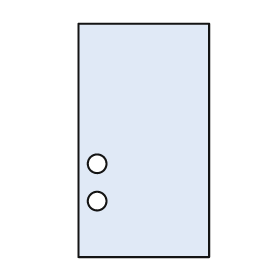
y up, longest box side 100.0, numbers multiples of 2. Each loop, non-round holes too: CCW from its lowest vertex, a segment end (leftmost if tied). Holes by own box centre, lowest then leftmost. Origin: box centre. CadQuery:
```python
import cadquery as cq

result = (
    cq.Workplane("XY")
    .moveTo(-28.0, -50.0)
    .lineTo(28.0, -50.0)
    .lineTo(28.0, 50.0)
    .lineTo(-28.0, 50.0)
    .close()
    .moveTo(-20.0, -26.0)
    .circle(4.0)
    .moveTo(-20.0, -10.0)
    .circle(4.0)
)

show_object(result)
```